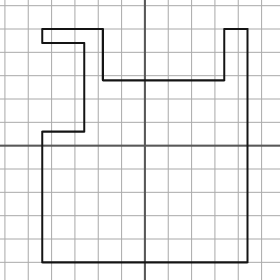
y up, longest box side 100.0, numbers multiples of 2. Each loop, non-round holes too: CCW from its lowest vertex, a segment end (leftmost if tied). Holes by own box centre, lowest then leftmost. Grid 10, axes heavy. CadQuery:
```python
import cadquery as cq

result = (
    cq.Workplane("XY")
    .moveTo(-44.0, -50.0)
    .lineTo(44.0, -50.0)
    .lineTo(44.0, 50.0)
    .lineTo(34.0, 50.0)
    .lineTo(34.0, 28.0)
    .lineTo(-18.0, 28.0)
    .lineTo(-18.0, 50.0)
    .lineTo(-44.0, 50.0)
    .lineTo(-44.0, 44.0)
    .lineTo(-26.0, 44.0)
    .lineTo(-26.0, 6.0)
    .lineTo(-44.0, 6.0)
    .close()
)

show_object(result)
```